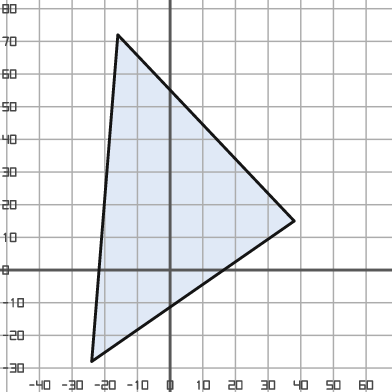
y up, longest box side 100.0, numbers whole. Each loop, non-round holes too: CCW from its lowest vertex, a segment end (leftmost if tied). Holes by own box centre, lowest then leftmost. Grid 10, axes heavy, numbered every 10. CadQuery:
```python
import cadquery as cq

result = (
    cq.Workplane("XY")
    .moveTo(-24.0, -28.0)
    .lineTo(38.0, 15.0)
    .lineTo(-16.0, 72.0)
    .close()
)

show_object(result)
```